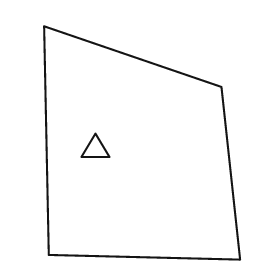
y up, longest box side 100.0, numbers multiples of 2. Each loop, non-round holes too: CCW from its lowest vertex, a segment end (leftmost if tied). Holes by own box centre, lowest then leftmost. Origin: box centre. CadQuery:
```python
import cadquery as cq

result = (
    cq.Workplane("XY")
    .moveTo(42.0, -50.0)
    .lineTo(34.0, 24.0)
    .lineTo(-42.0, 50.0)
    .lineTo(-40.0, -48.0)
    .close()
    .moveTo(-26.0, -6.0)
    .lineTo(-14.0, -6.0)
    .lineTo(-20.0, 4.0)
    .close()
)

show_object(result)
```